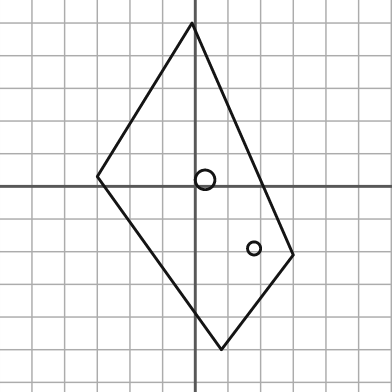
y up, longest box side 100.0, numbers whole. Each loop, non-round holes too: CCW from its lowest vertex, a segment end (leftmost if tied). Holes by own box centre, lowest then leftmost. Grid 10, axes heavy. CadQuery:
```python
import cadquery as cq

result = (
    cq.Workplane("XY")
    .moveTo(8.0, -50.0)
    .lineTo(30.0, -21.0)
    .lineTo(-1.0, 50.0)
    .lineTo(-30.0, 3.0)
    .close()
    .moveTo(18.0, -19.0)
    .circle(2.0)
    .moveTo(3.0, 2.0)
    .circle(3.0)
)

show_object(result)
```